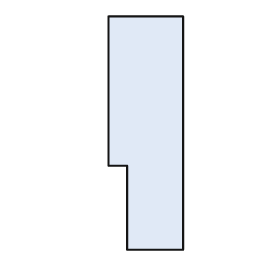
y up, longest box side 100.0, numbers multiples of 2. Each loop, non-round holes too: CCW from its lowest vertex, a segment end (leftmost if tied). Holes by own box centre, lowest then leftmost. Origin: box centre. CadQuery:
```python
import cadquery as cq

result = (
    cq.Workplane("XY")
    .moveTo(-8.0, -50.0)
    .lineTo(16.0, -50.0)
    .lineTo(16.0, 50.0)
    .lineTo(-16.0, 50.0)
    .lineTo(-16.0, -14.0)
    .lineTo(-8.0, -14.0)
    .close()
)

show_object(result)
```